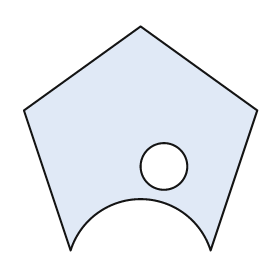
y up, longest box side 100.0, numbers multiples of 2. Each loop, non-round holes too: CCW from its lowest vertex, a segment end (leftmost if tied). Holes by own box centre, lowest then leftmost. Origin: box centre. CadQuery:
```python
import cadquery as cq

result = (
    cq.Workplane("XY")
    .moveTo(-30.0, -48.0)
    .threePointArc((0.0, -26.0), (30.0, -48.0))
    .lineTo(50.0, 12.0)
    .lineTo(0.0, 48.0)
    .lineTo(-50.0, 12.0)
    .close()
    .moveTo(10.0, -12.0)
    .circle(10.0)
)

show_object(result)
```